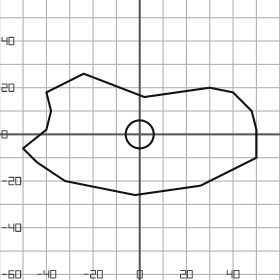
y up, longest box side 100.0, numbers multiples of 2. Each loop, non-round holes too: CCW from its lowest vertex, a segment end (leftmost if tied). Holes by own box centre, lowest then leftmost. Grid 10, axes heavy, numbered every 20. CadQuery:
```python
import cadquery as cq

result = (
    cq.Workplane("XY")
    .moveTo(-2.0, -26.0)
    .lineTo(26.0, -22.0)
    .lineTo(50.0, -10.0)
    .lineTo(50.0, 2.0)
    .lineTo(48.0, 10.0)
    .lineTo(40.0, 18.0)
    .lineTo(30.0, 20.0)
    .lineTo(2.0, 16.0)
    .lineTo(-24.0, 26.0)
    .lineTo(-40.0, 18.0)
    .lineTo(-38.0, 10.0)
    .lineTo(-40.0, 2.0)
    .lineTo(-50.0, -6.0)
    .lineTo(-44.0, -12.0)
    .lineTo(-32.0, -20.0)
    .close()
    .moveTo(0.0, 0.0)
    .circle(6.0)
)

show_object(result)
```